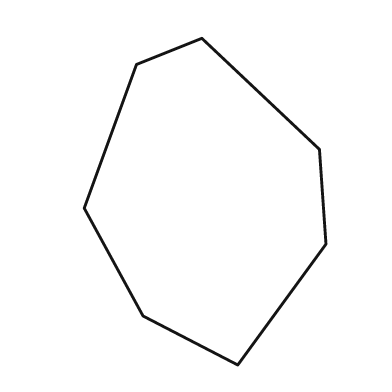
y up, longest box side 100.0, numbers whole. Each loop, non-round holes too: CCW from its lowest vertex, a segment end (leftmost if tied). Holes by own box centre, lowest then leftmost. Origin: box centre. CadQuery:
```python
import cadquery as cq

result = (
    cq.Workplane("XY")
    .moveTo(10.0, -50.0)
    .lineTo(37.0, -13.0)
    .lineTo(35.0, 16.0)
    .lineTo(-1.0, 50.0)
    .lineTo(-21.0, 42.0)
    .lineTo(-37.0, -2.0)
    .lineTo(-19.0, -35.0)
    .close()
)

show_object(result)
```